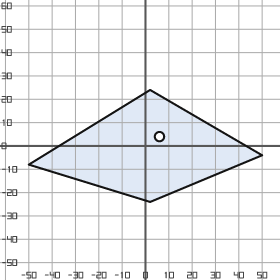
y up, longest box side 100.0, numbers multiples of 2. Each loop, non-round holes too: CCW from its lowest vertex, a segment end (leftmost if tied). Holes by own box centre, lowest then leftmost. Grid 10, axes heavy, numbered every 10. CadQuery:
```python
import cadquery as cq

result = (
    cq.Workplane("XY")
    .moveTo(2.0, -24.0)
    .lineTo(50.0, -4.0)
    .lineTo(2.0, 24.0)
    .lineTo(-50.0, -8.0)
    .close()
    .moveTo(6.0, 4.0)
    .circle(2.0)
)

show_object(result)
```